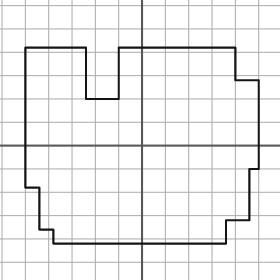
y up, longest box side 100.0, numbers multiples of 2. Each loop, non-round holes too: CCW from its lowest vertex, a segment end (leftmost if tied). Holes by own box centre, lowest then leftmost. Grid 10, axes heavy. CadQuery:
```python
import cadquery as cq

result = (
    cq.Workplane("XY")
    .moveTo(-38.0, -42.0)
    .lineTo(36.0, -42.0)
    .lineTo(36.0, -32.0)
    .lineTo(46.0, -32.0)
    .lineTo(46.0, -10.0)
    .lineTo(50.0, -10.0)
    .lineTo(50.0, 28.0)
    .lineTo(40.0, 28.0)
    .lineTo(40.0, 42.0)
    .lineTo(-10.0, 42.0)
    .lineTo(-10.0, 20.0)
    .lineTo(-24.0, 20.0)
    .lineTo(-24.0, 42.0)
    .lineTo(-50.0, 42.0)
    .lineTo(-50.0, -18.0)
    .lineTo(-44.0, -18.0)
    .lineTo(-44.0, -36.0)
    .lineTo(-38.0, -36.0)
    .close()
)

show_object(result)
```